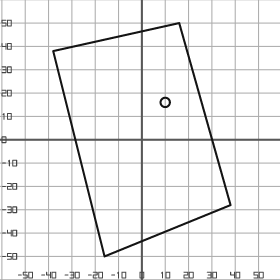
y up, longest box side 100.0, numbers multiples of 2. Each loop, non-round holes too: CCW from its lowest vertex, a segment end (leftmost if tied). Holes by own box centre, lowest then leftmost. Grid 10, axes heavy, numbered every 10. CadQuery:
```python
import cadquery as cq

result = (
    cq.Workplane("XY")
    .moveTo(-16.0, -50.0)
    .lineTo(38.0, -28.0)
    .lineTo(16.0, 50.0)
    .lineTo(-38.0, 38.0)
    .close()
    .moveTo(10.0, 16.0)
    .circle(2.0)
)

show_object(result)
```